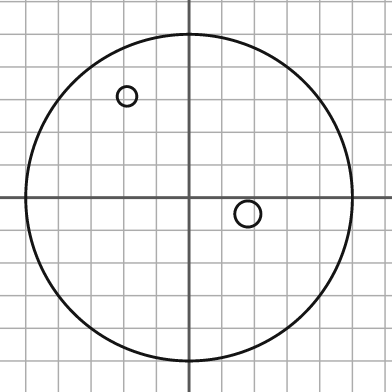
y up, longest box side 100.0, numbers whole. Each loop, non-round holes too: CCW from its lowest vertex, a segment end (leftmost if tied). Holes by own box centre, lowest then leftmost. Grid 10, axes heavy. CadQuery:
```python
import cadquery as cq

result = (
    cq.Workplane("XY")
    .moveTo(0.0, 0.0)
    .circle(50.0)
    .moveTo(18.0, -5.0)
    .circle(4.0)
    .moveTo(-19.0, 31.0)
    .circle(3.0)
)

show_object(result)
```